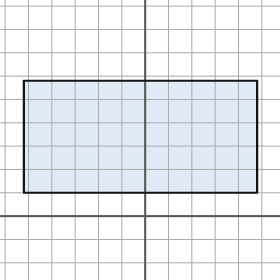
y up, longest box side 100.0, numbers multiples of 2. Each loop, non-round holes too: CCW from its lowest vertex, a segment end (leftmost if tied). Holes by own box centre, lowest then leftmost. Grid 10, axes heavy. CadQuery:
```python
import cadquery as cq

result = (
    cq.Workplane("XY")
    .moveTo(-52.0, 10.0)
    .lineTo(48.0, 10.0)
    .lineTo(48.0, 58.0)
    .lineTo(-52.0, 58.0)
    .close()
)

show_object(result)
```